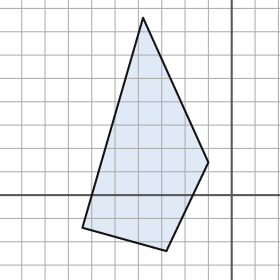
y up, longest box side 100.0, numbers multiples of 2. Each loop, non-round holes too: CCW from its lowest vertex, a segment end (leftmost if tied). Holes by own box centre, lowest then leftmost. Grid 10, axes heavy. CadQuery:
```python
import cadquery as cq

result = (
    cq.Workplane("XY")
    .moveTo(-28.0, -24.0)
    .lineTo(-10.0, 14.0)
    .lineTo(-38.0, 76.0)
    .lineTo(-64.0, -14.0)
    .close()
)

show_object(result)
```